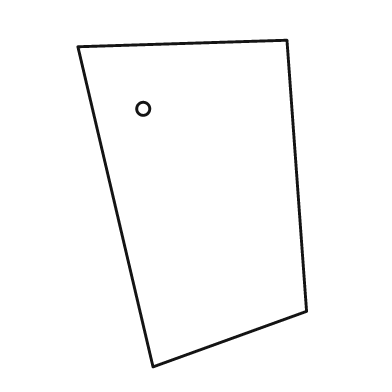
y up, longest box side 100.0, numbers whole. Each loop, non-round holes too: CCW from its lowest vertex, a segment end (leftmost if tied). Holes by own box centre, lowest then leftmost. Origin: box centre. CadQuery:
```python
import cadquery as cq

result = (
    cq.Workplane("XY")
    .moveTo(-12.0, -50.0)
    .lineTo(35.0, -33.0)
    .lineTo(29.0, 50.0)
    .lineTo(-35.0, 48.0)
    .close()
    .moveTo(-15.0, 29.0)
    .circle(2.0)
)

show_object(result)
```